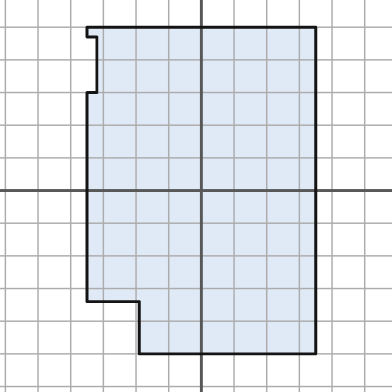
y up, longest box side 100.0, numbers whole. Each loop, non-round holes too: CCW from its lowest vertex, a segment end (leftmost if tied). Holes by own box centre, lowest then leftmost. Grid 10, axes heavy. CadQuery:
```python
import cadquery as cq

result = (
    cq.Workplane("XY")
    .moveTo(-19.0, -50.0)
    .lineTo(35.0, -50.0)
    .lineTo(35.0, 50.0)
    .lineTo(-35.0, 50.0)
    .lineTo(-35.0, 47.0)
    .lineTo(-32.0, 47.0)
    .lineTo(-32.0, 30.0)
    .lineTo(-35.0, 30.0)
    .lineTo(-35.0, -34.0)
    .lineTo(-19.0, -34.0)
    .close()
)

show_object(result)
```